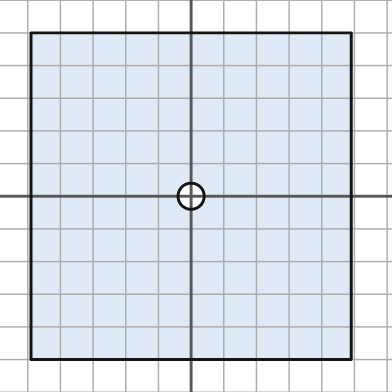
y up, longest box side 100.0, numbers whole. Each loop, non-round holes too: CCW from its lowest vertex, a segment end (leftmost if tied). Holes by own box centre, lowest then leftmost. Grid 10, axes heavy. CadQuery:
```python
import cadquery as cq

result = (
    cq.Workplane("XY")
    .moveTo(-49.0, -50.0)
    .lineTo(49.0, -50.0)
    .lineTo(49.0, 50.0)
    .lineTo(-49.0, 50.0)
    .close()
    .moveTo(0.0, 0.0)
    .circle(4.0)
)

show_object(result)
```